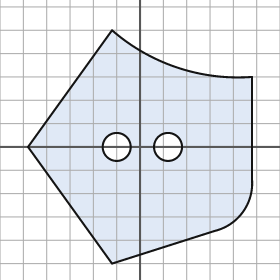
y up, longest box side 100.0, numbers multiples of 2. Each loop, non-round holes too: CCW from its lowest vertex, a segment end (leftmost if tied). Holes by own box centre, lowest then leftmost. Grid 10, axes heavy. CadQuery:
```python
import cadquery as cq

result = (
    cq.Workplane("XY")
    .moveTo(-12.0, -50.0)
    .lineTo(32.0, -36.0)
    .threePointArc((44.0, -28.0), (48.0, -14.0))
    .lineTo(48.0, 30.0)
    .threePointArc((16.0, 34.0), (-12.0, 50.0))
    .lineTo(-48.0, 0.0)
    .close()
    .moveTo(-10.0, 0.0)
    .circle(6.0)
    .moveTo(12.0, 0.0)
    .circle(6.0)
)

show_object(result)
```